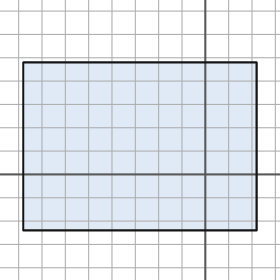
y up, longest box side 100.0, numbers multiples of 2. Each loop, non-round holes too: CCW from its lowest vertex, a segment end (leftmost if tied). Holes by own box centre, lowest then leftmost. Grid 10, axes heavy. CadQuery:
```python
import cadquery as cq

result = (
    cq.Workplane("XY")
    .moveTo(-78.0, -24.0)
    .lineTo(22.0, -24.0)
    .lineTo(22.0, 48.0)
    .lineTo(-78.0, 48.0)
    .close()
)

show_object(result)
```